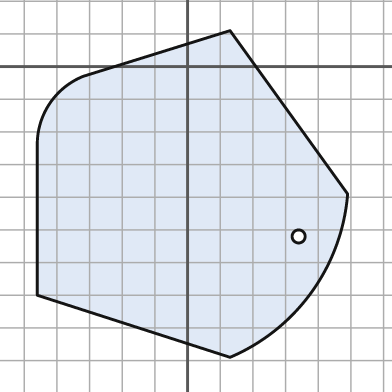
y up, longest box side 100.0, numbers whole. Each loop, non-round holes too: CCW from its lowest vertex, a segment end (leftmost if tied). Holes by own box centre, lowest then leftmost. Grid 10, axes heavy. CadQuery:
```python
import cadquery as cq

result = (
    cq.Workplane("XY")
    .moveTo(13.0, -89.0)
    .threePointArc((38.0, -69.0), (49.0, -39.0))
    .lineTo(13.0, 11.0)
    .lineTo(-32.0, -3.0)
    .threePointArc((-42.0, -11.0), (-46.0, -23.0))
    .lineTo(-46.0, -70.0)
    .close()
    .moveTo(34.0, -52.0)
    .circle(2.0)
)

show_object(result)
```